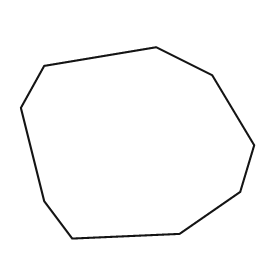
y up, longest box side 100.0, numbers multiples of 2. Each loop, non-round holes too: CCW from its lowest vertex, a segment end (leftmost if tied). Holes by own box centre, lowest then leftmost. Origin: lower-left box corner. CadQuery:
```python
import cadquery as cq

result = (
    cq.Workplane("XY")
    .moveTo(22.0, 0.0)
    .lineTo(68.0, 2.0)
    .lineTo(94.0, 20.0)
    .lineTo(100.0, 40.0)
    .lineTo(82.0, 70.0)
    .lineTo(58.0, 82.0)
    .lineTo(10.0, 74.0)
    .lineTo(0.0, 56.0)
    .lineTo(10.0, 16.0)
    .close()
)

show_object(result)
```